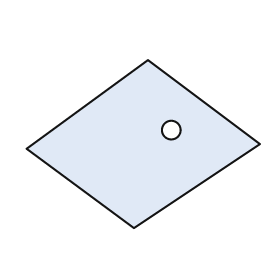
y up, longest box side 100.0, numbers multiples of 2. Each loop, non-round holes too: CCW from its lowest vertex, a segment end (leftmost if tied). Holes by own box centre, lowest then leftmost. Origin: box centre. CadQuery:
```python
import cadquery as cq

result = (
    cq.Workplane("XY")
    .moveTo(-4.0, -36.0)
    .lineTo(50.0, 0.0)
    .lineTo(2.0, 36.0)
    .lineTo(-50.0, -2.0)
    .close()
    .moveTo(12.0, 6.0)
    .circle(4.0)
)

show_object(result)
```